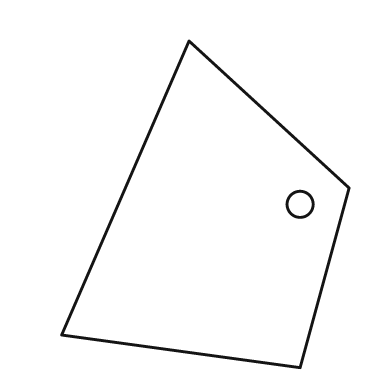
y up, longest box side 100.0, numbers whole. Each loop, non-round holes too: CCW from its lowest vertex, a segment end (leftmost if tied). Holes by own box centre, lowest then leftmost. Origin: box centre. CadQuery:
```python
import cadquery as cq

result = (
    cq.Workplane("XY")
    .moveTo(29.0, -50.0)
    .lineTo(44.0, 5.0)
    .lineTo(-5.0, 50.0)
    .lineTo(-44.0, -40.0)
    .close()
    .moveTo(29.0, 0.0)
    .circle(4.0)
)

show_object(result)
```